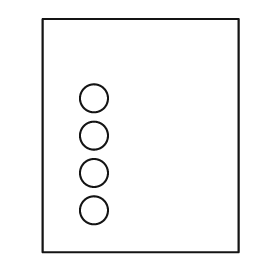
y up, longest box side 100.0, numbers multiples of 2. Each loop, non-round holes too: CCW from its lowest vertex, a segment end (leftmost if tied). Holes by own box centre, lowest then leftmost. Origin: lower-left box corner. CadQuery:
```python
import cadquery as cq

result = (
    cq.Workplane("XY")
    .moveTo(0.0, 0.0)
    .lineTo(84.0, 0.0)
    .lineTo(84.0, 100.0)
    .lineTo(0.0, 100.0)
    .close()
    .moveTo(22.0, 18.0)
    .circle(6.0)
    .moveTo(22.0, 34.0)
    .circle(6.0)
    .moveTo(22.0, 50.0)
    .circle(6.0)
    .moveTo(22.0, 66.0)
    .circle(6.0)
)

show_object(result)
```